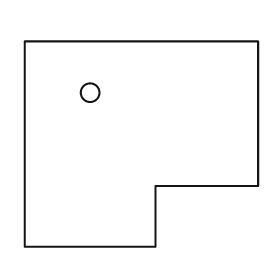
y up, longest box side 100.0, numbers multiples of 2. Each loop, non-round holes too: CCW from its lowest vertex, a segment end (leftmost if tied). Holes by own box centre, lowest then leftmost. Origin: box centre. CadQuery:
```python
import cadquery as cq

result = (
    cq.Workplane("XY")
    .moveTo(-50.0, -44.0)
    .lineTo(6.0, -44.0)
    .lineTo(6.0, -18.0)
    .lineTo(50.0, -18.0)
    .lineTo(50.0, 44.0)
    .lineTo(-50.0, 44.0)
    .close()
    .moveTo(-22.0, 22.0)
    .circle(4.0)
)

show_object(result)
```